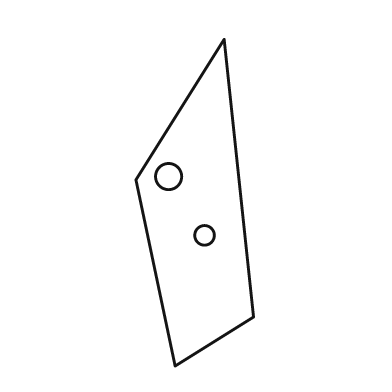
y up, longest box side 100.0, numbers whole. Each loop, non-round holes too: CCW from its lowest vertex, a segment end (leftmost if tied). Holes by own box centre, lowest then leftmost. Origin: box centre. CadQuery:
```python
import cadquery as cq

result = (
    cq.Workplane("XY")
    .moveTo(-6.0, -50.0)
    .lineTo(18.0, -35.0)
    .lineTo(9.0, 50.0)
    .lineTo(-18.0, 7.0)
    .close()
    .moveTo(3.0, -10.0)
    .circle(3.0)
    .moveTo(-8.0, 8.0)
    .circle(4.0)
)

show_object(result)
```